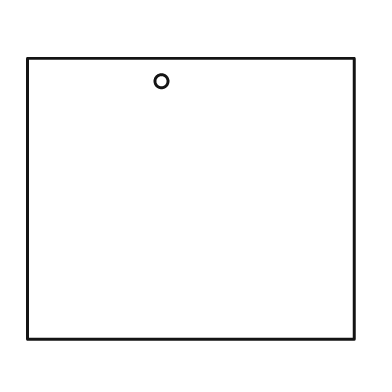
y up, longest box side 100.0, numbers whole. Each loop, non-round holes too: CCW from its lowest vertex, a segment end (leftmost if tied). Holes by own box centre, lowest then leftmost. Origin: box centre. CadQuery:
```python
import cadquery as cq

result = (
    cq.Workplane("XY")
    .moveTo(-50.0, -43.0)
    .lineTo(50.0, -43.0)
    .lineTo(50.0, 43.0)
    .lineTo(-50.0, 43.0)
    .close()
    .moveTo(-9.0, 36.0)
    .circle(2.0)
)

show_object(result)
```